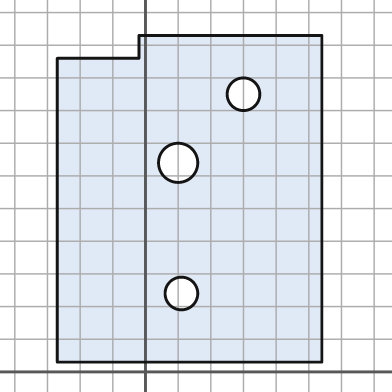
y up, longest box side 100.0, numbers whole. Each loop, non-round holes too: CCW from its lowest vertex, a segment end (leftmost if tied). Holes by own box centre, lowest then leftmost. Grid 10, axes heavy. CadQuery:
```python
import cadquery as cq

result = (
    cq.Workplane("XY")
    .moveTo(-27.0, 3.0)
    .lineTo(54.0, 3.0)
    .lineTo(54.0, 103.0)
    .lineTo(-2.0, 103.0)
    .lineTo(-2.0, 96.0)
    .lineTo(-27.0, 96.0)
    .close()
    .moveTo(11.0, 24.0)
    .circle(5.0)
    .moveTo(10.0, 64.0)
    .circle(6.0)
    .moveTo(30.0, 85.0)
    .circle(5.0)
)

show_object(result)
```